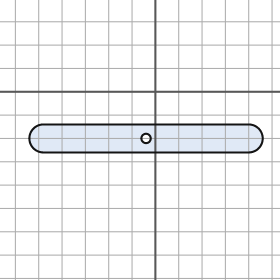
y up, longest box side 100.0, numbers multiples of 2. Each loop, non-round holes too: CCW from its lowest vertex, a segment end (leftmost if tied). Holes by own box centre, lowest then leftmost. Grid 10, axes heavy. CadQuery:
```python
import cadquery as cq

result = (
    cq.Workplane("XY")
    .moveTo(-48.0, -26.0)
    .lineTo(40.0, -26.0)
    .threePointArc((46.0, -20.0), (40.0, -14.0))
    .lineTo(-48.0, -14.0)
    .threePointArc((-54.0, -20.0), (-48.0, -26.0))
    .close()
    .moveTo(-4.0, -20.0)
    .circle(2.0)
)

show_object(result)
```